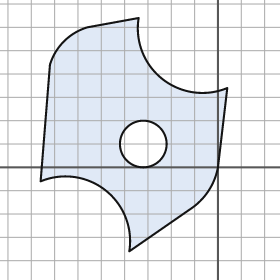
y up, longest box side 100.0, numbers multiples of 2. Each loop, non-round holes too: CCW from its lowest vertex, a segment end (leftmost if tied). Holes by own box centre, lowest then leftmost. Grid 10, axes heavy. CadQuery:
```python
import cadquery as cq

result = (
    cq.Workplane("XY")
    .moveTo(-38.0, -36.0)
    .lineTo(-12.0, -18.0)
    .threePointArc((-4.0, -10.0), (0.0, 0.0))
    .lineTo(4.0, 34.0)
    .threePointArc((-24.0, 38.0), (-34.0, 64.0))
    .lineTo(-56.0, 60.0)
    .threePointArc((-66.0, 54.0), (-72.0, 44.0))
    .lineTo(-76.0, -6.0)
    .threePointArc((-48.0, -10.0), (-38.0, -36.0))
    .close()
    .moveTo(-32.0, 10.0)
    .circle(10.0)
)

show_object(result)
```